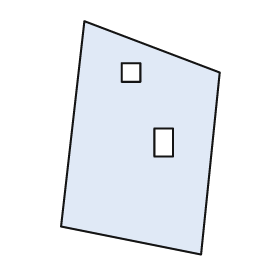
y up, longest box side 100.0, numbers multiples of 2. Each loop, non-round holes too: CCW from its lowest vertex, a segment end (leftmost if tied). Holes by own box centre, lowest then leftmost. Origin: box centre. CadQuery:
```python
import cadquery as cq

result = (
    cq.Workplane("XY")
    .moveTo(26.0, -50.0)
    .lineTo(34.0, 28.0)
    .lineTo(-24.0, 50.0)
    .lineTo(-34.0, -38.0)
    .close()
    .moveTo(6.0, -8.0)
    .lineTo(14.0, -8.0)
    .lineTo(14.0, 4.0)
    .lineTo(6.0, 4.0)
    .close()
    .moveTo(-8.0, 24.0)
    .lineTo(0.0, 24.0)
    .lineTo(0.0, 32.0)
    .lineTo(-8.0, 32.0)
    .close()
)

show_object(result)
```